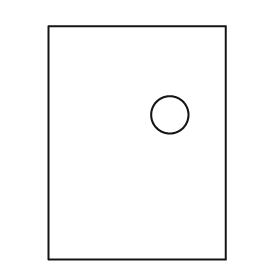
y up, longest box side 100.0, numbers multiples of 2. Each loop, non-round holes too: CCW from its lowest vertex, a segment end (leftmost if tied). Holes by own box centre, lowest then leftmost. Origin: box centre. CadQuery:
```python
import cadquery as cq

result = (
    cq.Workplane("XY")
    .moveTo(-38.0, -50.0)
    .lineTo(38.0, -50.0)
    .lineTo(38.0, 50.0)
    .lineTo(-38.0, 50.0)
    .close()
    .moveTo(14.0, 12.0)
    .circle(8.0)
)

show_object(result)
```